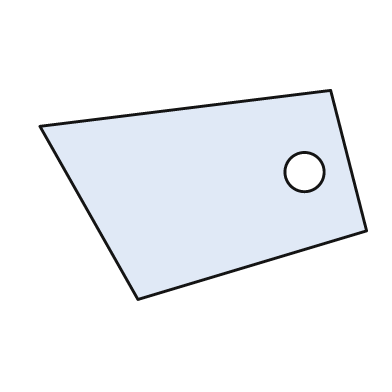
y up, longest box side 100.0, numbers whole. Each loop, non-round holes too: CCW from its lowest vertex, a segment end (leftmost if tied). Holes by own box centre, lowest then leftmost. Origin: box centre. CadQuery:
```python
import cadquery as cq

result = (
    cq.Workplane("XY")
    .moveTo(-20.0, -32.0)
    .lineTo(50.0, -11.0)
    .lineTo(39.0, 32.0)
    .lineTo(-50.0, 21.0)
    .close()
    .moveTo(31.0, 7.0)
    .circle(6.0)
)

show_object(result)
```